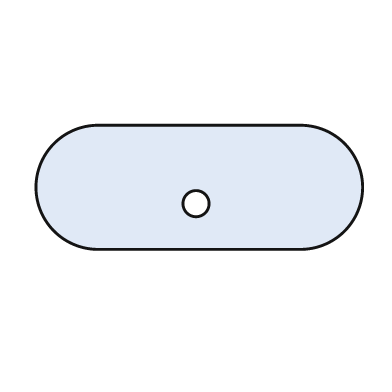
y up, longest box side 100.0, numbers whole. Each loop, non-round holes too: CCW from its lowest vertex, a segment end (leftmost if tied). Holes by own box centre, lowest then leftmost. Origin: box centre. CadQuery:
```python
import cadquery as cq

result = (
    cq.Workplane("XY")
    .moveTo(-31.0, -19.0)
    .lineTo(31.0, -19.0)
    .threePointArc((50.0, 0.0), (31.0, 19.0))
    .lineTo(-31.0, 19.0)
    .threePointArc((-50.0, 0.0), (-31.0, -19.0))
    .close()
    .moveTo(-1.0, -5.0)
    .circle(4.0)
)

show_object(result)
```